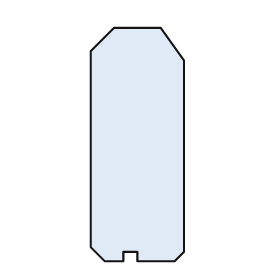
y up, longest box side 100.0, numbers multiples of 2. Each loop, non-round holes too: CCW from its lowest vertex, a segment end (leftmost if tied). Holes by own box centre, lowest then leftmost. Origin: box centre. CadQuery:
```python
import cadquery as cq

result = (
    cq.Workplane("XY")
    .moveTo(-14.0, -50.0)
    .lineTo(-6.0, -50.0)
    .lineTo(-6.0, -46.0)
    .lineTo(0.0, -46.0)
    .lineTo(0.0, -50.0)
    .lineTo(16.0, -50.0)
    .lineTo(20.0, -46.0)
    .lineTo(20.0, 36.0)
    .lineTo(10.0, 50.0)
    .lineTo(-10.0, 50.0)
    .lineTo(-20.0, 40.0)
    .lineTo(-20.0, -44.0)
    .close()
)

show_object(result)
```